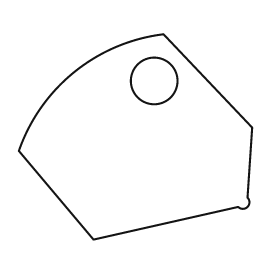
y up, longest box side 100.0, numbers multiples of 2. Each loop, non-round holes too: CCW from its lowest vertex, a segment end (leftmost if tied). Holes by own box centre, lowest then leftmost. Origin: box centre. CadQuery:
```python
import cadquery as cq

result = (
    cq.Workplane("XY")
    .moveTo(-18.0, -44.0)
    .lineTo(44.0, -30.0)
    .threePointArc((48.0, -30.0), (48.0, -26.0))
    .lineTo(50.0, 4.0)
    .lineTo(12.0, 44.0)
    .threePointArc((-26.0, 28.0), (-50.0, -6.0))
    .close()
    .moveTo(8.0, 24.0)
    .circle(10.0)
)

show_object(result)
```